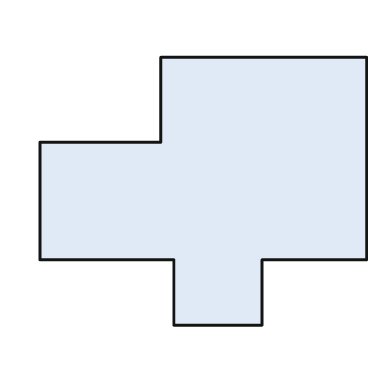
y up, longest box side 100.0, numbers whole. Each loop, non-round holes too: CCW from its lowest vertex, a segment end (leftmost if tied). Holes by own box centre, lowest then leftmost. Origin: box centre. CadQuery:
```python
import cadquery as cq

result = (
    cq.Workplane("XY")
    .moveTo(-9.0, -41.0)
    .lineTo(18.0, -41.0)
    .lineTo(18.0, -21.0)
    .lineTo(50.0, -21.0)
    .lineTo(50.0, 41.0)
    .lineTo(-13.0, 41.0)
    .lineTo(-13.0, 15.0)
    .lineTo(-50.0, 15.0)
    .lineTo(-50.0, -21.0)
    .lineTo(-9.0, -21.0)
    .close()
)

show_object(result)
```